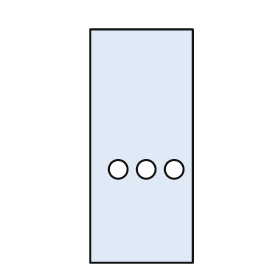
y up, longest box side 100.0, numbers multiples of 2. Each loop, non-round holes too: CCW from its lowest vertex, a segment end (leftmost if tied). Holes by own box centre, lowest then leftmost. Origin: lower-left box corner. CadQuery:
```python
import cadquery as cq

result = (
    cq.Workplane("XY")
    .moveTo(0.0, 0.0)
    .lineTo(44.0, 0.0)
    .lineTo(44.0, 100.0)
    .lineTo(0.0, 100.0)
    .close()
    .moveTo(12.0, 40.0)
    .circle(4.0)
    .moveTo(24.0, 40.0)
    .circle(4.0)
    .moveTo(36.0, 40.0)
    .circle(4.0)
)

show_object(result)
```